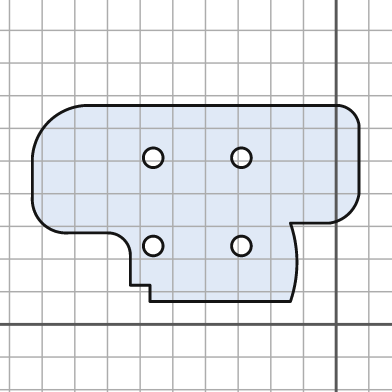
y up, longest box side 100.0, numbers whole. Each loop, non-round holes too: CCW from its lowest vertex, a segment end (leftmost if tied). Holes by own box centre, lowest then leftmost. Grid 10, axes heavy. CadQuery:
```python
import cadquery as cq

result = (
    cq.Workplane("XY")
    .moveTo(-57.0, 7.0)
    .lineTo(-14.0, 7.0)
    .threePointArc((-12.0, 19.0), (-14.0, 31.0))
    .lineTo(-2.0, 31.0)
    .threePointArc((4.0, 34.0), (7.0, 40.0))
    .lineTo(7.0, 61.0)
    .threePointArc((5.0, 65.0), (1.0, 67.0))
    .lineTo(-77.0, 67.0)
    .threePointArc((-88.0, 62.0), (-93.0, 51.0))
    .lineTo(-93.0, 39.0)
    .threePointArc((-90.0, 31.0), (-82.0, 28.0))
    .lineTo(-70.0, 28.0)
    .threePointArc((-65.0, 26.0), (-63.0, 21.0))
    .lineTo(-63.0, 12.0)
    .lineTo(-57.0, 12.0)
    .close()
    .moveTo(-56.0, 24.0)
    .circle(3.0)
    .moveTo(-29.0, 24.0)
    .circle(3.0)
    .moveTo(-56.0, 51.0)
    .circle(3.0)
    .moveTo(-29.0, 51.0)
    .circle(3.0)
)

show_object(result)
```